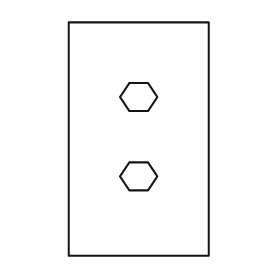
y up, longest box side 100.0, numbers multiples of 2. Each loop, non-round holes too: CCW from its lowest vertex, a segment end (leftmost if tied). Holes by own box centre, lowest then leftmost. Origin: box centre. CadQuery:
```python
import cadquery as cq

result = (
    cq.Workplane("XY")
    .moveTo(-30.0, -50.0)
    .lineTo(30.0, -50.0)
    .lineTo(30.0, 50.0)
    .lineTo(-30.0, 50.0)
    .close()
    .moveTo(-4.0, -22.0)
    .lineTo(4.0, -22.0)
    .lineTo(8.0, -16.0)
    .lineTo(4.0, -10.0)
    .lineTo(-4.0, -10.0)
    .lineTo(-8.0, -16.0)
    .close()
    .moveTo(-4.0, 12.0)
    .lineTo(4.0, 12.0)
    .lineTo(8.0, 18.0)
    .lineTo(4.0, 24.0)
    .lineTo(-4.0, 24.0)
    .lineTo(-8.0, 18.0)
    .close()
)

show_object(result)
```